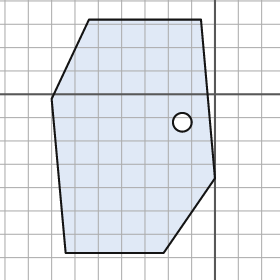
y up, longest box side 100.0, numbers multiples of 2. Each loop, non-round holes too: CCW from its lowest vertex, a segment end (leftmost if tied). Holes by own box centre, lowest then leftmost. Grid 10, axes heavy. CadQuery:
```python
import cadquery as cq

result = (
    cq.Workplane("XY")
    .moveTo(-64.0, -68.0)
    .lineTo(-22.0, -68.0)
    .lineTo(0.0, -36.0)
    .lineTo(-6.0, 32.0)
    .lineTo(-54.0, 32.0)
    .lineTo(-70.0, -2.0)
    .close()
    .moveTo(-14.0, -12.0)
    .circle(4.0)
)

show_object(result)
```